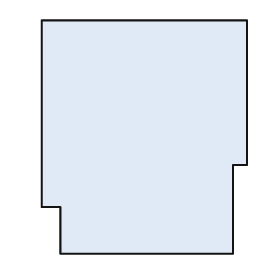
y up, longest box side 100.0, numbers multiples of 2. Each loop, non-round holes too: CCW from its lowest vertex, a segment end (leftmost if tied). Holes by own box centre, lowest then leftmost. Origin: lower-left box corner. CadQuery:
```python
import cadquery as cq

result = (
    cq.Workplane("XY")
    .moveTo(8.0, 0.0)
    .lineTo(82.0, 0.0)
    .lineTo(82.0, 38.0)
    .lineTo(88.0, 38.0)
    .lineTo(88.0, 100.0)
    .lineTo(0.0, 100.0)
    .lineTo(0.0, 20.0)
    .lineTo(8.0, 20.0)
    .close()
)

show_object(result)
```